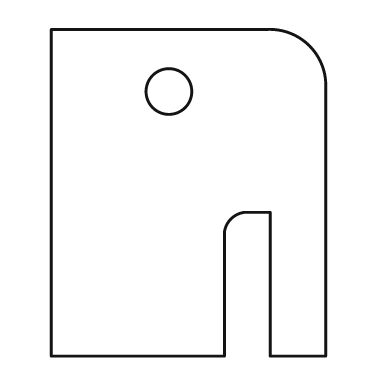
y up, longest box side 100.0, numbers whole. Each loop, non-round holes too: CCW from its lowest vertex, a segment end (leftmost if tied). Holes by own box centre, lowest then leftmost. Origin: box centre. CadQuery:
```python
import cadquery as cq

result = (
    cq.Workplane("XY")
    .moveTo(-42.0, -50.0)
    .lineTo(11.0, -50.0)
    .lineTo(11.0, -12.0)
    .threePointArc((13.0, -8.0), (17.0, -6.0))
    .lineTo(25.0, -6.0)
    .lineTo(25.0, -50.0)
    .lineTo(42.0, -50.0)
    .lineTo(42.0, 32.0)
    .threePointArc((37.0, 45.0), (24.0, 50.0))
    .lineTo(-42.0, 50.0)
    .close()
    .moveTo(-6.0, 31.0)
    .circle(7.0)
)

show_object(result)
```